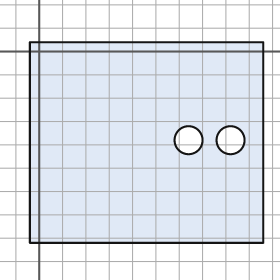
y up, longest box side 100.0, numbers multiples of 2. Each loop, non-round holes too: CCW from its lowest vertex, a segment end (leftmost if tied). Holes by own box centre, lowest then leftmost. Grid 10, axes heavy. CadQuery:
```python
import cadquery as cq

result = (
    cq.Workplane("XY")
    .moveTo(-4.0, -82.0)
    .lineTo(96.0, -82.0)
    .lineTo(96.0, 4.0)
    .lineTo(-4.0, 4.0)
    .close()
    .moveTo(64.0, -38.0)
    .circle(6.0)
    .moveTo(82.0, -38.0)
    .circle(6.0)
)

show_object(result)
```